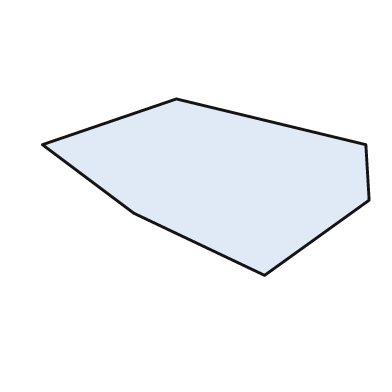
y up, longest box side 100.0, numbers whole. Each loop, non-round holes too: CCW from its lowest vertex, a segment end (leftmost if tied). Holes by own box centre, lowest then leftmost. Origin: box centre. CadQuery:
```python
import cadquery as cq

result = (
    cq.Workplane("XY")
    .moveTo(18.0, -27.0)
    .lineTo(50.0, -4.0)
    .lineTo(49.0, 13.0)
    .lineTo(-9.0, 27.0)
    .lineTo(-50.0, 13.0)
    .lineTo(-22.0, -8.0)
    .close()
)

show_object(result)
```